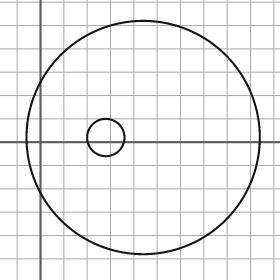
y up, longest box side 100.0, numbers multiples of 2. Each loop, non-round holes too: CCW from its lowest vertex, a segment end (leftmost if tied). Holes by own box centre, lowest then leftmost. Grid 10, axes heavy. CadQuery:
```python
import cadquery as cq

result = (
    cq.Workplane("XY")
    .moveTo(44.0, 2.0)
    .circle(50.0)
    .moveTo(28.0, 2.0)
    .circle(8.0)
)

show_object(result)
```